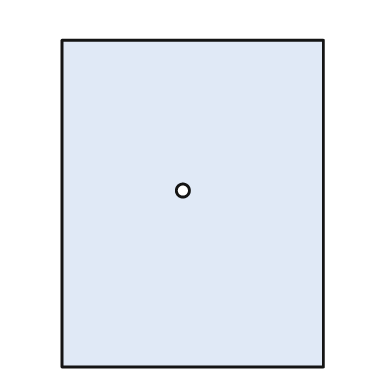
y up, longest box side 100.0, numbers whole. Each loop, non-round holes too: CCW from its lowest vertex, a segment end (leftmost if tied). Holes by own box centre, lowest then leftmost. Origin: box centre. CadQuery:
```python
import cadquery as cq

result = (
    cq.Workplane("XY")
    .moveTo(-40.0, -50.0)
    .lineTo(40.0, -50.0)
    .lineTo(40.0, 50.0)
    .lineTo(-40.0, 50.0)
    .close()
    .moveTo(-3.0, 4.0)
    .circle(2.0)
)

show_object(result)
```